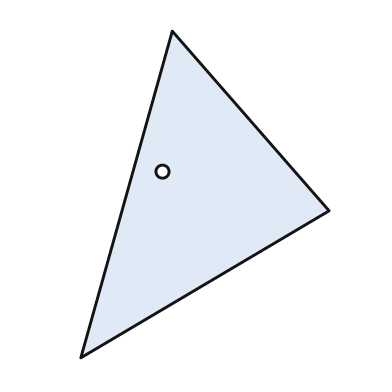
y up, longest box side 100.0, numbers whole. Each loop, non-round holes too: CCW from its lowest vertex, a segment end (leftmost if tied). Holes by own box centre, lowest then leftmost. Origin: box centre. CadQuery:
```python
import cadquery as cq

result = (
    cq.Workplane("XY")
    .moveTo(-38.0, -50.0)
    .lineTo(38.0, -5.0)
    .lineTo(-10.0, 50.0)
    .close()
    .moveTo(-13.0, 7.0)
    .circle(2.0)
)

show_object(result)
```